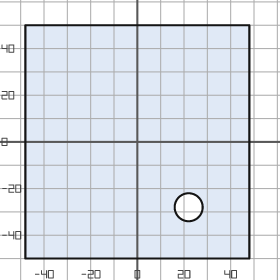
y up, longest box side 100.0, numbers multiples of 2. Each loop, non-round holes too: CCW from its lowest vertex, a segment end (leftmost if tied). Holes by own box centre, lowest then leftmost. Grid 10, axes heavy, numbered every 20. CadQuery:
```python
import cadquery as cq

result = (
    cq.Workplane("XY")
    .moveTo(-48.0, -50.0)
    .lineTo(48.0, -50.0)
    .lineTo(48.0, 50.0)
    .lineTo(-48.0, 50.0)
    .close()
    .moveTo(22.0, -28.0)
    .circle(6.0)
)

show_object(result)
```